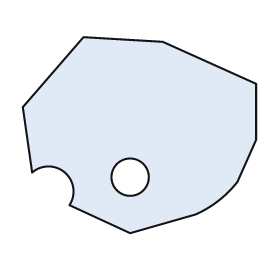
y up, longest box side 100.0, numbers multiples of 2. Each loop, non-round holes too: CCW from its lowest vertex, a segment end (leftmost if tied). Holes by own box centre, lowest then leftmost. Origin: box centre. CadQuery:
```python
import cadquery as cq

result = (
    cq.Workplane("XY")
    .moveTo(-4.0, -42.0)
    .lineTo(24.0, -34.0)
    .threePointArc((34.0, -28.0), (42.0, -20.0))
    .lineTo(50.0, -2.0)
    .lineTo(50.0, 22.0)
    .lineTo(10.0, 40.0)
    .lineTo(-24.0, 42.0)
    .lineTo(-50.0, 12.0)
    .lineTo(-46.0, -16.0)
    .threePointArc((-32.0, -16.0), (-30.0, -30.0))
    .close()
    .moveTo(-4.0, -18.0)
    .circle(8.0)
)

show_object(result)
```